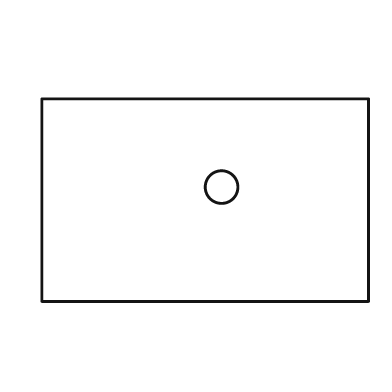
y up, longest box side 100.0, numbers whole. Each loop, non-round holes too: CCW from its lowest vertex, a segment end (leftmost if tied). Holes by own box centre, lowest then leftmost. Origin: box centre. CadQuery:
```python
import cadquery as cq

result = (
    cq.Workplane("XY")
    .moveTo(-50.0, -31.0)
    .lineTo(50.0, -31.0)
    .lineTo(50.0, 31.0)
    .lineTo(-50.0, 31.0)
    .close()
    .moveTo(5.0, 4.0)
    .circle(5.0)
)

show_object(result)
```